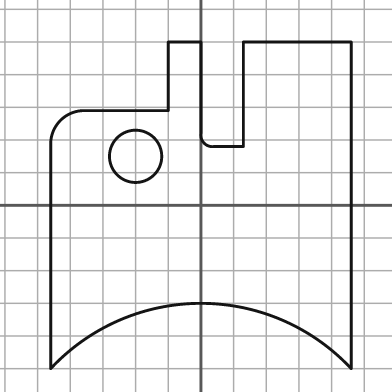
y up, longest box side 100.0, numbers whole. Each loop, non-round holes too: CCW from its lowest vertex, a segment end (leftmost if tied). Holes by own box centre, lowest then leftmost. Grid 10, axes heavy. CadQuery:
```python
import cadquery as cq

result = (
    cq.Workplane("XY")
    .moveTo(-46.0, -50.0)
    .threePointArc((0.0, -30.0), (46.0, -50.0))
    .lineTo(46.0, 50.0)
    .lineTo(13.0, 50.0)
    .lineTo(13.0, 18.0)
    .lineTo(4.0, 18.0)
    .threePointArc((1.0, 19.0), (0.0, 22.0))
    .lineTo(0.0, 50.0)
    .lineTo(-10.0, 50.0)
    .lineTo(-10.0, 29.0)
    .lineTo(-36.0, 29.0)
    .threePointArc((-43.0, 26.0), (-46.0, 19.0))
    .close()
    .moveTo(-20.0, 15.0)
    .circle(8.0)
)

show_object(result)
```